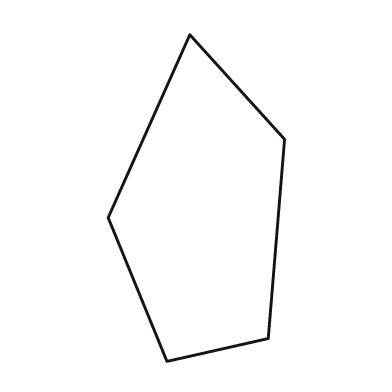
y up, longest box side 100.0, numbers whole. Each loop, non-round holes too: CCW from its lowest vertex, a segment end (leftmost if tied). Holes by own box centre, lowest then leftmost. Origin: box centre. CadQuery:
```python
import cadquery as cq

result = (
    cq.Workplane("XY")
    .moveTo(-9.0, -50.0)
    .lineTo(22.0, -43.0)
    .lineTo(27.0, 18.0)
    .lineTo(-2.0, 50.0)
    .lineTo(-27.0, -6.0)
    .close()
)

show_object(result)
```